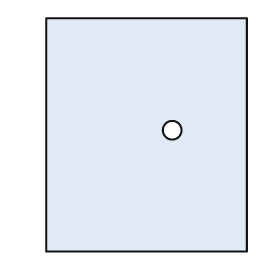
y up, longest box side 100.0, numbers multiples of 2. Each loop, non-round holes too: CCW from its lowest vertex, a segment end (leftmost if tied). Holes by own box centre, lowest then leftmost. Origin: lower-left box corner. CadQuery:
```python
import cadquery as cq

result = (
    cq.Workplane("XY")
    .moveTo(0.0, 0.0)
    .lineTo(86.0, 0.0)
    .lineTo(86.0, 100.0)
    .lineTo(0.0, 100.0)
    .close()
    .moveTo(54.0, 52.0)
    .circle(4.0)
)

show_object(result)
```